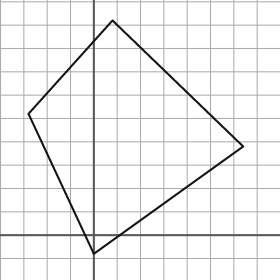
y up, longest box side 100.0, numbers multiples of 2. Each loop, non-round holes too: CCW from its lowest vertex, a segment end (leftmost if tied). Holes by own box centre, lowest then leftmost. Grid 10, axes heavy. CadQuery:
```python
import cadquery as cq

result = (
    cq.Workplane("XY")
    .moveTo(0.0, -8.0)
    .lineTo(64.0, 38.0)
    .lineTo(8.0, 92.0)
    .lineTo(-28.0, 52.0)
    .close()
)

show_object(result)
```